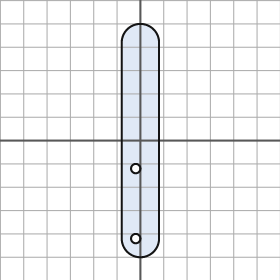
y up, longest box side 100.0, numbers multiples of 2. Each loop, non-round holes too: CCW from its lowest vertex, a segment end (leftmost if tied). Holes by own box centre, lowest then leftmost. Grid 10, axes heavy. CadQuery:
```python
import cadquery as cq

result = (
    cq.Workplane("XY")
    .moveTo(-8.0, -42.0)
    .threePointArc((0.0, -50.0), (8.0, -42.0))
    .lineTo(8.0, 42.0)
    .threePointArc((0.0, 50.0), (-8.0, 42.0))
    .close()
    .moveTo(-2.0, -42.0)
    .circle(2.0)
    .moveTo(-2.0, -12.0)
    .circle(2.0)
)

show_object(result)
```